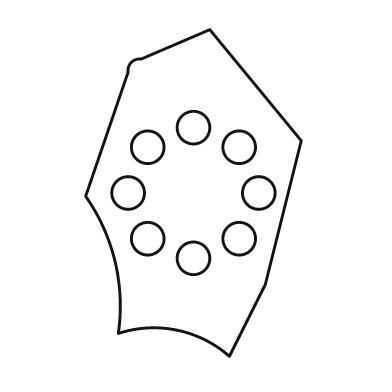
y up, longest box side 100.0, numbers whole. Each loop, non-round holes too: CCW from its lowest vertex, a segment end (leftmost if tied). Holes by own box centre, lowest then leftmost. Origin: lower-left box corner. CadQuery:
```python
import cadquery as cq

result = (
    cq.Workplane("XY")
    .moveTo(44.0, 0.0)
    .lineTo(55.0, 22.0)
    .lineTo(66.0, 66.0)
    .lineTo(38.0, 100.0)
    .lineTo(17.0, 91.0)
    .threePointArc((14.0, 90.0), (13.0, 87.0))
    .lineTo(0.0, 49.0)
    .threePointArc((9.0, 29.0), (10.0, 7.0))
    .threePointArc((28.0, 8.0), (44.0, 0.0))
    .close()
    .moveTo(33.0, 30.0)
    .circle(5.0)
    .moveTo(19.0, 36.0)
    .circle(5.0)
    .moveTo(47.0, 36.0)
    .circle(5.0)
    .moveTo(13.0, 50.0)
    .circle(5.0)
    .moveTo(53.0, 50.0)
    .circle(5.0)
    .moveTo(19.0, 64.0)
    .circle(5.0)
    .moveTo(47.0, 64.0)
    .circle(5.0)
    .moveTo(33.0, 70.0)
    .circle(5.0)
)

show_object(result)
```